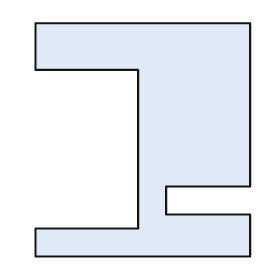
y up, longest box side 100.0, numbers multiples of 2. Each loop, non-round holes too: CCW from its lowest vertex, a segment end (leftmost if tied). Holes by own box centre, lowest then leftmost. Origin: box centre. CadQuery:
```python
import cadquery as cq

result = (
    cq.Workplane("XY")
    .moveTo(-46.0, -50.0)
    .lineTo(46.0, -50.0)
    .lineTo(46.0, -32.0)
    .lineTo(10.0, -32.0)
    .lineTo(10.0, -20.0)
    .lineTo(46.0, -20.0)
    .lineTo(46.0, 50.0)
    .lineTo(-46.0, 50.0)
    .lineTo(-46.0, 30.0)
    .lineTo(-2.0, 30.0)
    .lineTo(-2.0, -38.0)
    .lineTo(-46.0, -38.0)
    .close()
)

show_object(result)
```